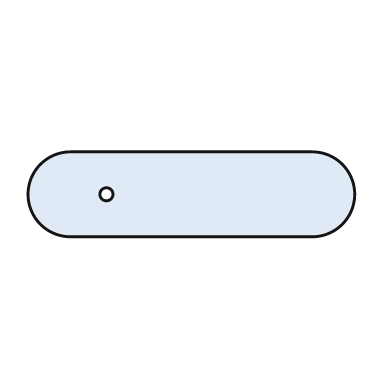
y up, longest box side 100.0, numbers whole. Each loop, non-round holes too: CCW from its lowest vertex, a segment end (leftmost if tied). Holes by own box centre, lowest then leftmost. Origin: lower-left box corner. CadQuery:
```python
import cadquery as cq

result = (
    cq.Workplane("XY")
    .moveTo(13.0, 0.0)
    .lineTo(87.0, 0.0)
    .threePointArc((100.0, 13.0), (87.0, 26.0))
    .lineTo(13.0, 26.0)
    .threePointArc((0.0, 13.0), (13.0, 0.0))
    .close()
    .moveTo(24.0, 13.0)
    .circle(2.0)
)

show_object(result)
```